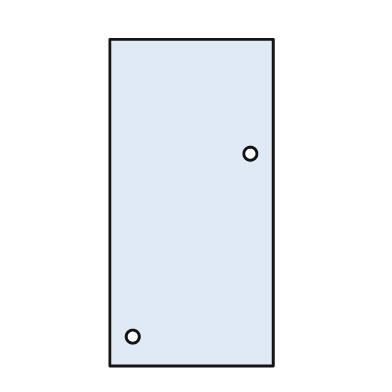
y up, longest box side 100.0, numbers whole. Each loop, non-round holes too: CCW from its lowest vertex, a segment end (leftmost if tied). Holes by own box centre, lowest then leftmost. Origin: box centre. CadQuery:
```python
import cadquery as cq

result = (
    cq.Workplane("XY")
    .moveTo(-25.0, -50.0)
    .lineTo(25.0, -50.0)
    .lineTo(25.0, 50.0)
    .lineTo(-25.0, 50.0)
    .close()
    .moveTo(-18.0, -41.0)
    .circle(2.0)
    .moveTo(18.0, 15.0)
    .circle(2.0)
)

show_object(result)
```